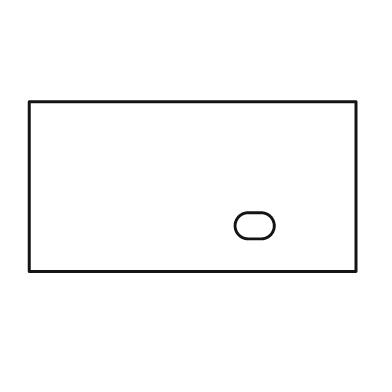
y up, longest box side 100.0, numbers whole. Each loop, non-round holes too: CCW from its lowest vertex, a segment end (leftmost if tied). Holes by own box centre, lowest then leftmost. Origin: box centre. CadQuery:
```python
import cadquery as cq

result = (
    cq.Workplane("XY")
    .moveTo(-50.0, -26.0)
    .lineTo(50.0, -26.0)
    .lineTo(50.0, 26.0)
    .lineTo(-50.0, 26.0)
    .close()
    .moveTo(17.0, -16.0)
    .lineTo(21.0, -16.0)
    .threePointArc((25.0, -12.0), (21.0, -8.0))
    .lineTo(17.0, -8.0)
    .threePointArc((13.0, -12.0), (17.0, -16.0))
    .close()
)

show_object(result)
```